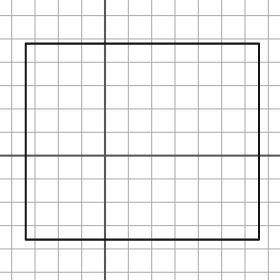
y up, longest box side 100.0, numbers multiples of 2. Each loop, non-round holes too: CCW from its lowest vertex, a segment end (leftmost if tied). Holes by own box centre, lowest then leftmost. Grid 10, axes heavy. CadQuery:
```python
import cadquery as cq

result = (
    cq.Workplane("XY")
    .moveTo(-34.0, -36.0)
    .lineTo(66.0, -36.0)
    .lineTo(66.0, 48.0)
    .lineTo(-34.0, 48.0)
    .close()
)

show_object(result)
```